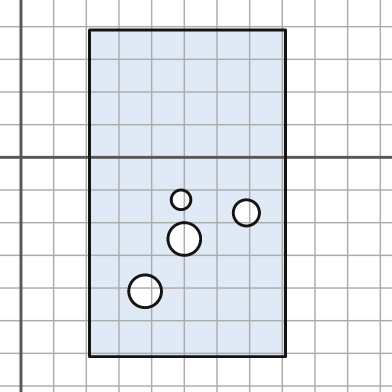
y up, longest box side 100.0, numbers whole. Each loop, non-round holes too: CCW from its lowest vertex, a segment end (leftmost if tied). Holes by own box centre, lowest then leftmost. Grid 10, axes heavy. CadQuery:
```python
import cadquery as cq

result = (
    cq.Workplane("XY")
    .moveTo(21.0, -61.0)
    .lineTo(81.0, -61.0)
    .lineTo(81.0, 39.0)
    .lineTo(21.0, 39.0)
    .close()
    .moveTo(38.0, -41.0)
    .circle(5.0)
    .moveTo(50.0, -25.0)
    .circle(5.0)
    .moveTo(69.0, -17.0)
    .circle(4.0)
    .moveTo(49.0, -13.0)
    .circle(3.0)
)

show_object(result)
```